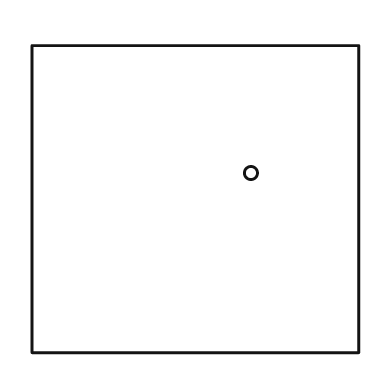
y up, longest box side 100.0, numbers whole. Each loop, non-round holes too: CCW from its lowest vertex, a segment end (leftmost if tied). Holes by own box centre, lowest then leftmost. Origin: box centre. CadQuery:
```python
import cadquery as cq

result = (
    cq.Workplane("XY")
    .moveTo(-50.0, -47.0)
    .lineTo(50.0, -47.0)
    .lineTo(50.0, 47.0)
    .lineTo(-50.0, 47.0)
    .close()
    .moveTo(17.0, 8.0)
    .circle(2.0)
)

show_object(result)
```